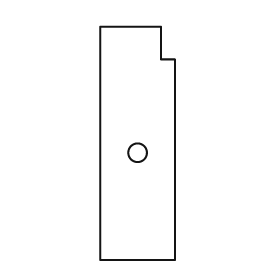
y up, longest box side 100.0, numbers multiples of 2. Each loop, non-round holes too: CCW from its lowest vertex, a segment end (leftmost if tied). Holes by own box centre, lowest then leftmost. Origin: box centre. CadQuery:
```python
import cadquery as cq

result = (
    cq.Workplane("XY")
    .moveTo(-16.0, -50.0)
    .lineTo(16.0, -50.0)
    .lineTo(16.0, 36.0)
    .lineTo(10.0, 36.0)
    .lineTo(10.0, 50.0)
    .lineTo(-16.0, 50.0)
    .close()
    .moveTo(0.0, -4.0)
    .circle(4.0)
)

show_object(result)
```